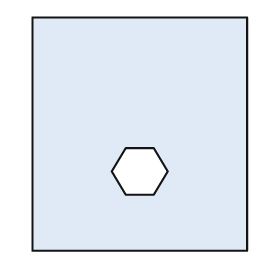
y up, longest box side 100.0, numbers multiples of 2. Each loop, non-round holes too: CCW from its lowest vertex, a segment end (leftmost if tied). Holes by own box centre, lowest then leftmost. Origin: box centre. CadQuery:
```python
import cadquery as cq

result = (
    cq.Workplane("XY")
    .moveTo(-46.0, -50.0)
    .lineTo(46.0, -50.0)
    .lineTo(46.0, 50.0)
    .lineTo(-46.0, 50.0)
    .close()
    .moveTo(-6.0, -26.0)
    .lineTo(6.0, -26.0)
    .lineTo(12.0, -16.0)
    .lineTo(6.0, -6.0)
    .lineTo(-6.0, -6.0)
    .lineTo(-12.0, -16.0)
    .close()
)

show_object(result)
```